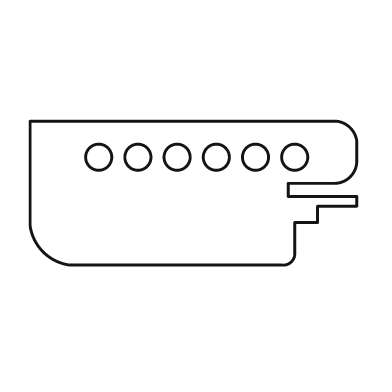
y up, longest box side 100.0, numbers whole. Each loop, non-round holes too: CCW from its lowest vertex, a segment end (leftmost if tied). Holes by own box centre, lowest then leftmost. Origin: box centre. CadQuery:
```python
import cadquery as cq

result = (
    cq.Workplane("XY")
    .moveTo(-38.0, -22.0)
    .lineTo(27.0, -22.0)
    .threePointArc((30.0, -21.0), (31.0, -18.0))
    .lineTo(31.0, -9.0)
    .lineTo(38.0, -9.0)
    .lineTo(38.0, -4.0)
    .lineTo(50.0, -4.0)
    .lineTo(50.0, -1.0)
    .lineTo(29.0, -1.0)
    .lineTo(29.0, 3.0)
    .lineTo(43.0, 3.0)
    .threePointArc((48.0, 5.0), (50.0, 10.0))
    .lineTo(50.0, 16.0)
    .threePointArc((48.0, 20.0), (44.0, 22.0))
    .lineTo(-50.0, 22.0)
    .lineTo(-50.0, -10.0)
    .threePointArc((-46.0, -18.0), (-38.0, -22.0))
    .close()
    .moveTo(-29.0, 11.0)
    .circle(4.0)
    .moveTo(-17.0, 11.0)
    .circle(4.0)
    .moveTo(-5.0, 11.0)
    .circle(4.0)
    .moveTo(7.0, 11.0)
    .circle(4.0)
    .moveTo(19.0, 11.0)
    .circle(4.0)
    .moveTo(31.0, 11.0)
    .circle(4.0)
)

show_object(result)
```